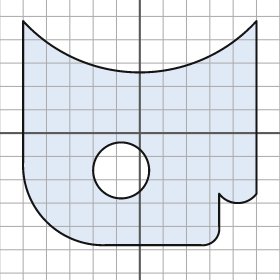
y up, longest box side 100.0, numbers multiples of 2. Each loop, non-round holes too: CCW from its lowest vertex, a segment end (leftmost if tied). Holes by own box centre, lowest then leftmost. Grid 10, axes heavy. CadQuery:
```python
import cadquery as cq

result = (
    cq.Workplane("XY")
    .moveTo(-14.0, -48.0)
    .lineTo(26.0, -48.0)
    .threePointArc((32.0, -46.0), (34.0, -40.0))
    .lineTo(34.0, -26.0)
    .threePointArc((42.0, -30.0), (50.0, -26.0))
    .lineTo(50.0, 48.0)
    .threePointArc((0.0, 26.0), (-50.0, 48.0))
    .lineTo(-50.0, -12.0)
    .threePointArc((-40.0, -38.0), (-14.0, -48.0))
    .close()
    .moveTo(-8.0, -16.0)
    .circle(12.0)
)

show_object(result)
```